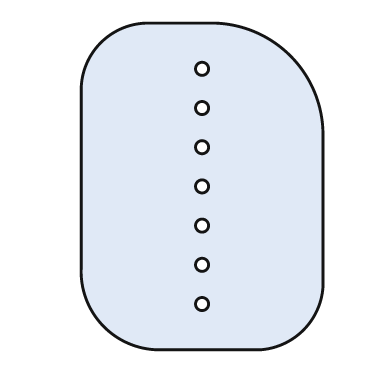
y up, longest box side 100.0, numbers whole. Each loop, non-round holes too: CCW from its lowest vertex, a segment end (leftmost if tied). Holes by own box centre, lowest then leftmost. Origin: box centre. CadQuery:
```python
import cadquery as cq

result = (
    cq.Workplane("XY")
    .moveTo(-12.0, -50.0)
    .lineTo(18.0, -50.0)
    .threePointArc((31.0, -44.0), (37.0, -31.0))
    .lineTo(37.0, 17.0)
    .threePointArc((27.0, 40.0), (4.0, 50.0))
    .lineTo(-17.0, 50.0)
    .threePointArc((-31.0, 44.0), (-37.0, 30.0))
    .lineTo(-37.0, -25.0)
    .threePointArc((-30.0, -43.0), (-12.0, -50.0))
    .close()
    .moveTo(0.0, -36.0)
    .circle(2.0)
    .moveTo(0.0, -24.0)
    .circle(2.0)
    .moveTo(0.0, -12.0)
    .circle(2.0)
    .moveTo(0.0, 0.0)
    .circle(2.0)
    .moveTo(0.0, 12.0)
    .circle(2.0)
    .moveTo(0.0, 24.0)
    .circle(2.0)
    .moveTo(0.0, 36.0)
    .circle(2.0)
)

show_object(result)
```